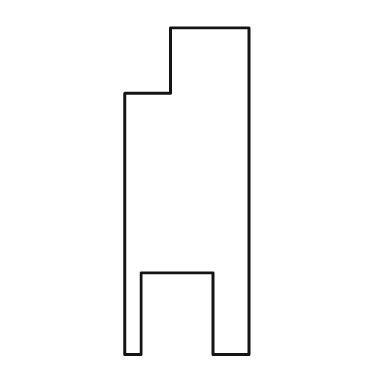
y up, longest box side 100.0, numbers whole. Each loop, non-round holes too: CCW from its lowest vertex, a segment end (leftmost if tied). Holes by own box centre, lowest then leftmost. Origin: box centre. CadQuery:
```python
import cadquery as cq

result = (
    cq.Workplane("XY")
    .moveTo(-19.0, -50.0)
    .lineTo(-14.0, -50.0)
    .lineTo(-14.0, -25.0)
    .lineTo(8.0, -25.0)
    .lineTo(8.0, -50.0)
    .lineTo(19.0, -50.0)
    .lineTo(19.0, 50.0)
    .lineTo(-5.0, 50.0)
    .lineTo(-5.0, 30.0)
    .lineTo(-19.0, 30.0)
    .close()
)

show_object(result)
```